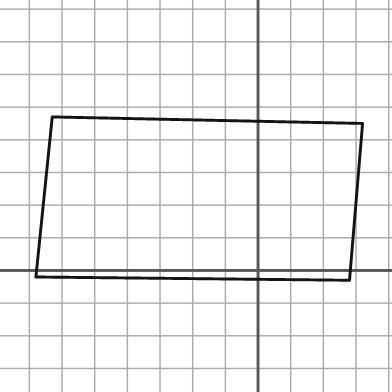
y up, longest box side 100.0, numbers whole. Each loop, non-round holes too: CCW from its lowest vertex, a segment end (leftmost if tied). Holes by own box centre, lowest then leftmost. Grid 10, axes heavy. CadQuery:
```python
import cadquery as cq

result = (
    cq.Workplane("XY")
    .moveTo(28.0, -3.0)
    .lineTo(32.0, 45.0)
    .lineTo(-63.0, 47.0)
    .lineTo(-68.0, -2.0)
    .close()
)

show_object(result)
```